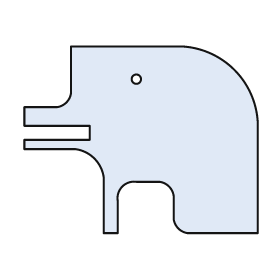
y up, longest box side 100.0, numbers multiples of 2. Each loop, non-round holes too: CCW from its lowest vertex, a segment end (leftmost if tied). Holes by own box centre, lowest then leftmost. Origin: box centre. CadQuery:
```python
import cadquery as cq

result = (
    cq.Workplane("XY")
    .moveTo(-16.0, -40.0)
    .lineTo(-10.0, -40.0)
    .lineTo(-10.0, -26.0)
    .threePointArc((-8.0, -20.0), (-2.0, -18.0))
    .lineTo(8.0, -18.0)
    .threePointArc((12.0, -20.0), (14.0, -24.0))
    .lineTo(14.0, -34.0)
    .threePointArc((16.0, -38.0), (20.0, -40.0))
    .lineTo(50.0, -40.0)
    .lineTo(50.0, 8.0)
    .threePointArc((40.0, 30.0), (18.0, 40.0))
    .lineTo(-30.0, 40.0)
    .lineTo(-30.0, 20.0)
    .threePointArc((-32.0, 16.0), (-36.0, 14.0))
    .lineTo(-50.0, 14.0)
    .lineTo(-50.0, 6.0)
    .lineTo(-22.0, 6.0)
    .lineTo(-22.0, 0.0)
    .lineTo(-50.0, 0.0)
    .lineTo(-50.0, -4.0)
    .lineTo(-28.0, -4.0)
    .threePointArc((-20.0, -8.0), (-16.0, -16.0))
    .close()
    .moveTo(-2.0, 26.0)
    .circle(2.0)
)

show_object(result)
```